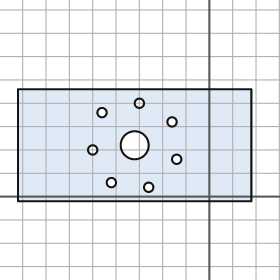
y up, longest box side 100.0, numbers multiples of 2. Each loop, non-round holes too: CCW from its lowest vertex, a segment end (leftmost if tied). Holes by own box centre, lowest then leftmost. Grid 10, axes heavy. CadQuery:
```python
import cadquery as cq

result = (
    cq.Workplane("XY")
    .moveTo(-82.0, -2.0)
    .lineTo(18.0, -2.0)
    .lineTo(18.0, 46.0)
    .lineTo(-82.0, 46.0)
    .close()
    .moveTo(-26.0, 4.0)
    .circle(2.0)
    .moveTo(-42.0, 6.0)
    .circle(2.0)
    .moveTo(-14.0, 16.0)
    .circle(2.0)
    .moveTo(-50.0, 20.0)
    .circle(2.0)
    .moveTo(-32.0, 22.0)
    .circle(6.0)
    .moveTo(-16.0, 32.0)
    .circle(2.0)
    .moveTo(-46.0, 36.0)
    .circle(2.0)
    .moveTo(-30.0, 40.0)
    .circle(2.0)
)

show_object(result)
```